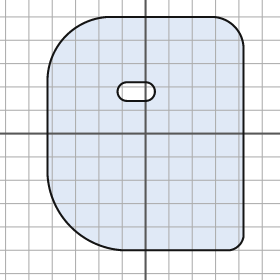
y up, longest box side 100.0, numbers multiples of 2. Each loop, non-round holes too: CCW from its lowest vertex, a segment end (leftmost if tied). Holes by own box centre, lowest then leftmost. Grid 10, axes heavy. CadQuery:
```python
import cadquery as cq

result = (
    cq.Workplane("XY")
    .moveTo(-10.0, -50.0)
    .lineTo(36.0, -50.0)
    .threePointArc((40.0, -48.0), (42.0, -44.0))
    .lineTo(42.0, 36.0)
    .threePointArc((38.0, 46.0), (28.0, 50.0))
    .lineTo(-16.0, 50.0)
    .threePointArc((-34.0, 42.0), (-42.0, 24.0))
    .lineTo(-42.0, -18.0)
    .threePointArc((-32.0, -40.0), (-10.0, -50.0))
    .close()
    .moveTo(-8.0, 14.0)
    .lineTo(0.0, 14.0)
    .threePointArc((4.0, 18.0), (0.0, 22.0))
    .lineTo(-8.0, 22.0)
    .threePointArc((-12.0, 18.0), (-8.0, 14.0))
    .close()
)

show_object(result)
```